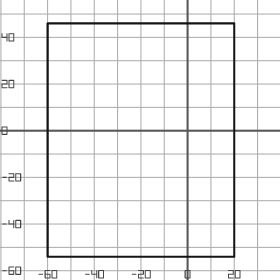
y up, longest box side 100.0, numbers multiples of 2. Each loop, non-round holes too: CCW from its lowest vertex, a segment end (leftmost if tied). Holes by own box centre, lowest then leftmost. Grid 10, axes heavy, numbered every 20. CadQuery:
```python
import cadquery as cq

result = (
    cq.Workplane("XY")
    .moveTo(-60.0, -54.0)
    .lineTo(20.0, -54.0)
    .lineTo(20.0, 46.0)
    .lineTo(-60.0, 46.0)
    .close()
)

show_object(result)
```